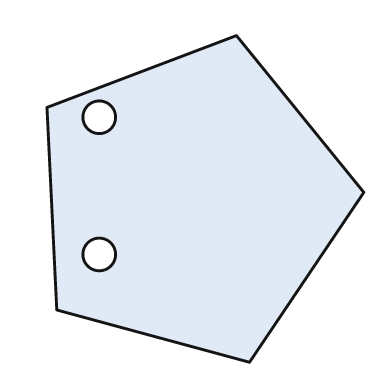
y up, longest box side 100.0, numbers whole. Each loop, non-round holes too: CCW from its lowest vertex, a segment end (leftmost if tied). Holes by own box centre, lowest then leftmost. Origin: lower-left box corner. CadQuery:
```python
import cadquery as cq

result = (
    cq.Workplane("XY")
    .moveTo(62.0, 0.0)
    .lineTo(97.0, 52.0)
    .lineTo(58.0, 100.0)
    .lineTo(0.0, 78.0)
    .lineTo(3.0, 16.0)
    .close()
    .moveTo(16.0, 33.0)
    .circle(5.0)
    .moveTo(16.0, 75.0)
    .circle(5.0)
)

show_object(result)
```